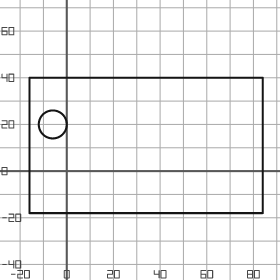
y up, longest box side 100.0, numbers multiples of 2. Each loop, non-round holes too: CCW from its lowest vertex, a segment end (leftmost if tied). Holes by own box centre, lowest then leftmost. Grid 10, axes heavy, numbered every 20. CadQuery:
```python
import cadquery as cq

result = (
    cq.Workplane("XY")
    .moveTo(-16.0, -18.0)
    .lineTo(84.0, -18.0)
    .lineTo(84.0, 40.0)
    .lineTo(-16.0, 40.0)
    .close()
    .moveTo(-6.0, 20.0)
    .circle(6.0)
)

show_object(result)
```